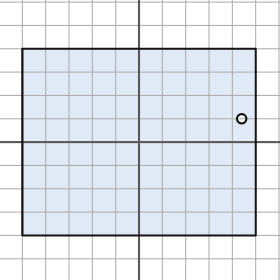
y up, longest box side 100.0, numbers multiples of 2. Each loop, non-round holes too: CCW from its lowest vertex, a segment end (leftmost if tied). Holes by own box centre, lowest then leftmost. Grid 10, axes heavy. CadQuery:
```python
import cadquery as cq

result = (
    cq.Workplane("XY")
    .moveTo(-50.0, -40.0)
    .lineTo(50.0, -40.0)
    .lineTo(50.0, 40.0)
    .lineTo(-50.0, 40.0)
    .close()
    .moveTo(44.0, 10.0)
    .circle(2.0)
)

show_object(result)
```